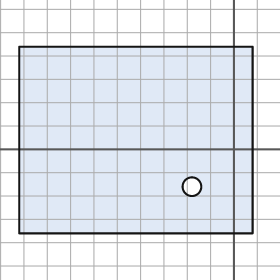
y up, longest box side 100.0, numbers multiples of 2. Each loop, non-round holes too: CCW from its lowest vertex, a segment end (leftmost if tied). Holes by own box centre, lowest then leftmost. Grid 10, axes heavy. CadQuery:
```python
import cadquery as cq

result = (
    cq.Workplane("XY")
    .moveTo(-92.0, -36.0)
    .lineTo(8.0, -36.0)
    .lineTo(8.0, 44.0)
    .lineTo(-92.0, 44.0)
    .close()
    .moveTo(-18.0, -16.0)
    .circle(4.0)
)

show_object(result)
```